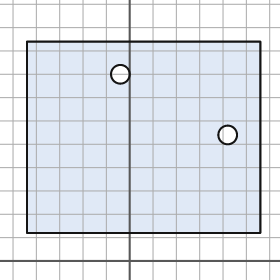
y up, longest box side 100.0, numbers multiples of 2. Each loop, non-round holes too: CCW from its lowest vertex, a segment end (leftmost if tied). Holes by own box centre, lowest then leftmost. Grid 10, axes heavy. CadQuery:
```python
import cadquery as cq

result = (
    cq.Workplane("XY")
    .moveTo(-44.0, 12.0)
    .lineTo(56.0, 12.0)
    .lineTo(56.0, 94.0)
    .lineTo(-44.0, 94.0)
    .close()
    .moveTo(42.0, 54.0)
    .circle(4.0)
    .moveTo(-4.0, 80.0)
    .circle(4.0)
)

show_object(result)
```